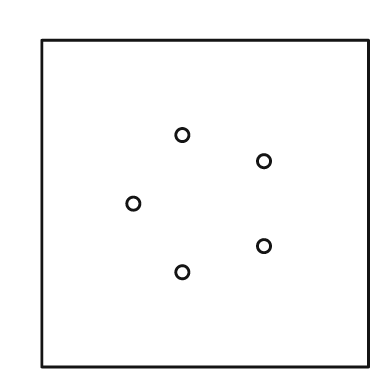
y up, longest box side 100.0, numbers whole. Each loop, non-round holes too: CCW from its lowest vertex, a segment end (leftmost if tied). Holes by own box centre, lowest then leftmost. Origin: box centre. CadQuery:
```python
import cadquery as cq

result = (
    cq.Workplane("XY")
    .moveTo(-50.0, -50.0)
    .lineTo(50.0, -50.0)
    .lineTo(50.0, 50.0)
    .lineTo(-50.0, 50.0)
    .close()
    .moveTo(-7.0, -21.0)
    .circle(2.0)
    .moveTo(18.0, -13.0)
    .circle(2.0)
    .moveTo(-22.0, 0.0)
    .circle(2.0)
    .moveTo(18.0, 13.0)
    .circle(2.0)
    .moveTo(-7.0, 21.0)
    .circle(2.0)
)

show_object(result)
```